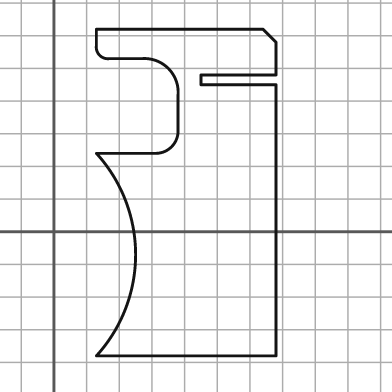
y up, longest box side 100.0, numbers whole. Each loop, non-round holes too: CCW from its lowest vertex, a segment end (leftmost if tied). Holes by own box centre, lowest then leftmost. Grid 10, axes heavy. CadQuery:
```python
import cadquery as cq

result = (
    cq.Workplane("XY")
    .moveTo(13.0, -38.0)
    .lineTo(68.0, -38.0)
    .lineTo(68.0, 45.0)
    .lineTo(45.0, 45.0)
    .lineTo(45.0, 48.0)
    .lineTo(68.0, 48.0)
    .lineTo(68.0, 58.0)
    .lineTo(64.0, 62.0)
    .lineTo(13.0, 62.0)
    .lineTo(13.0, 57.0)
    .threePointArc((14.0, 54.0), (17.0, 53.0))
    .lineTo(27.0, 53.0)
    .threePointArc((35.0, 50.0), (38.0, 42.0))
    .lineTo(38.0, 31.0)
    .threePointArc((36.0, 26.0), (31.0, 24.0))
    .lineTo(13.0, 24.0)
    .threePointArc((25.0, -7.0), (13.0, -38.0))
    .close()
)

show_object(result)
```